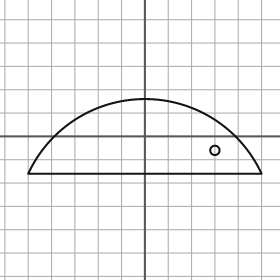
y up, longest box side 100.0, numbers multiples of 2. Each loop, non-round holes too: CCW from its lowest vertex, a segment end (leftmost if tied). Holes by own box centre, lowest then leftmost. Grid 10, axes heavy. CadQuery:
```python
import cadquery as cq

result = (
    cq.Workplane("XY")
    .moveTo(-50.0, -16.0)
    .lineTo(50.0, -16.0)
    .threePointArc((0.0, 16.0), (-50.0, -16.0))
    .close()
    .moveTo(30.0, -6.0)
    .circle(2.0)
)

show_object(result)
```